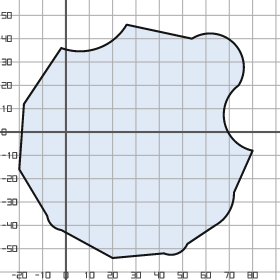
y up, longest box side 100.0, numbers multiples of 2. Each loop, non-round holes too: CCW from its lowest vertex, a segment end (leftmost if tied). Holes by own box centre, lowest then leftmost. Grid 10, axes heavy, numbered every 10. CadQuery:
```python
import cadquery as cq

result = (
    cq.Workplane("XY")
    .moveTo(20.0, -54.0)
    .lineTo(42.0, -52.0)
    .threePointArc((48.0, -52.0), (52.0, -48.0))
    .lineTo(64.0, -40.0)
    .threePointArc((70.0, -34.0), (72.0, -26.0))
    .lineTo(80.0, -8.0)
    .threePointArc((68.0, 4.0), (74.0, 20.0))
    .threePointArc((72.0, 38.0), (54.0, 40.0))
    .lineTo(26.0, 46.0)
    .threePointArc((14.0, 36.0), (-2.0, 36.0))
    .lineTo(-18.0, 12.0)
    .lineTo(-20.0, -16.0)
    .lineTo(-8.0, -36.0)
    .threePointArc((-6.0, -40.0), (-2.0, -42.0))
    .close()
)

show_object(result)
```